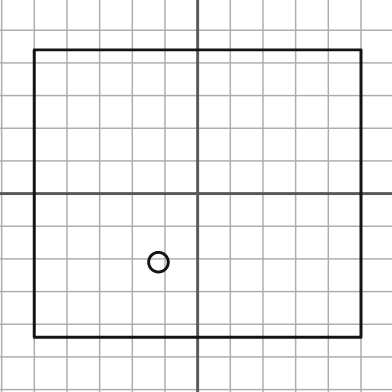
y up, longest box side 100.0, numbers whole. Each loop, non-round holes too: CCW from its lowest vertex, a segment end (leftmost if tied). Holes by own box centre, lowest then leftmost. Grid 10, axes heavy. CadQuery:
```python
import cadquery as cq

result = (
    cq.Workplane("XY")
    .moveTo(-50.0, -44.0)
    .lineTo(50.0, -44.0)
    .lineTo(50.0, 44.0)
    .lineTo(-50.0, 44.0)
    .close()
    .moveTo(-12.0, -21.0)
    .circle(3.0)
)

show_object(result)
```